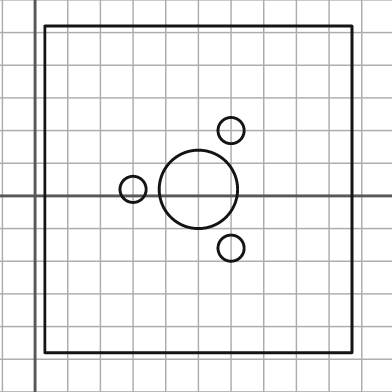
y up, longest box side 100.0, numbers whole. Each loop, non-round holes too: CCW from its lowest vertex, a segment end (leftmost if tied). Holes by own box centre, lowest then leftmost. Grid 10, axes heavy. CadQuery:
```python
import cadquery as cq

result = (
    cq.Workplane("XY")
    .moveTo(3.0, -48.0)
    .lineTo(97.0, -48.0)
    .lineTo(97.0, 52.0)
    .lineTo(3.0, 52.0)
    .close()
    .moveTo(60.0, -16.0)
    .circle(4.0)
    .moveTo(30.0, 2.0)
    .circle(4.0)
    .moveTo(50.0, 2.0)
    .circle(12.0)
    .moveTo(60.0, 20.0)
    .circle(4.0)
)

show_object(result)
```